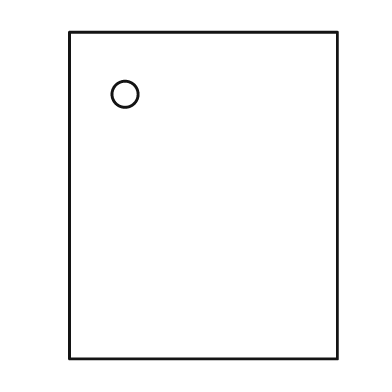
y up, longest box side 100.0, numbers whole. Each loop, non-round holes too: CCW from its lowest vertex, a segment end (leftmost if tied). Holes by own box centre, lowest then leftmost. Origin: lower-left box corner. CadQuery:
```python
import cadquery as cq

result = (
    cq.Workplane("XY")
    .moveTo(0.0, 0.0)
    .lineTo(82.0, 0.0)
    .lineTo(82.0, 100.0)
    .lineTo(0.0, 100.0)
    .close()
    .moveTo(17.0, 81.0)
    .circle(4.0)
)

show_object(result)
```